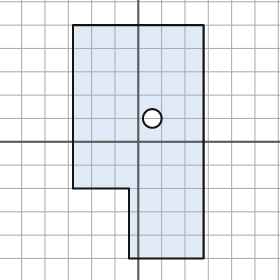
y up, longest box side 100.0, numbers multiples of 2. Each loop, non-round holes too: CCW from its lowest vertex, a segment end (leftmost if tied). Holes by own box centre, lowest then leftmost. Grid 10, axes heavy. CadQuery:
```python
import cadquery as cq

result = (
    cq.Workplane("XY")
    .moveTo(-4.0, -50.0)
    .lineTo(28.0, -50.0)
    .lineTo(28.0, 50.0)
    .lineTo(-28.0, 50.0)
    .lineTo(-28.0, -20.0)
    .lineTo(-4.0, -20.0)
    .close()
    .moveTo(6.0, 10.0)
    .circle(4.0)
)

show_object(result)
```